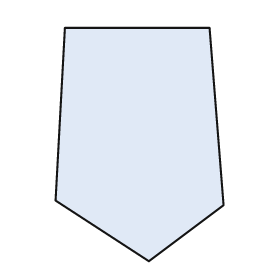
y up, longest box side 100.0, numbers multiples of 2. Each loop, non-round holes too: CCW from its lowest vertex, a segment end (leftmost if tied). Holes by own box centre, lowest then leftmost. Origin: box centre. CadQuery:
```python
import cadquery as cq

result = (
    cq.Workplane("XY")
    .moveTo(4.0, -50.0)
    .lineTo(36.0, -26.0)
    .lineTo(30.0, 50.0)
    .lineTo(-32.0, 50.0)
    .lineTo(-36.0, -24.0)
    .close()
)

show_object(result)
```